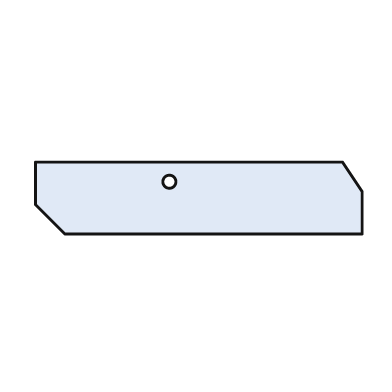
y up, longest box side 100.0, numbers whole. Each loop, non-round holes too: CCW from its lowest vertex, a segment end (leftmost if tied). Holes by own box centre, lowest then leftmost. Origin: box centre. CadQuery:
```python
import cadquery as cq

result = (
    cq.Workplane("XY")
    .moveTo(-41.0, -11.0)
    .lineTo(50.0, -11.0)
    .lineTo(50.0, 2.0)
    .lineTo(44.0, 11.0)
    .lineTo(-50.0, 11.0)
    .lineTo(-50.0, -2.0)
    .close()
    .moveTo(-9.0, 5.0)
    .circle(2.0)
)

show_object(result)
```